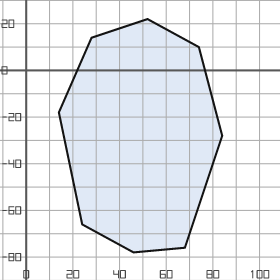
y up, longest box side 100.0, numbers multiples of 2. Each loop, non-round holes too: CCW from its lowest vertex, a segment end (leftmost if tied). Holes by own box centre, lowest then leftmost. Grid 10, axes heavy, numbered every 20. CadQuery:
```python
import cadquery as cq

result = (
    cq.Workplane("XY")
    .moveTo(46.0, -78.0)
    .lineTo(68.0, -76.0)
    .lineTo(84.0, -28.0)
    .lineTo(74.0, 10.0)
    .lineTo(52.0, 22.0)
    .lineTo(28.0, 14.0)
    .lineTo(14.0, -18.0)
    .lineTo(24.0, -66.0)
    .close()
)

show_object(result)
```